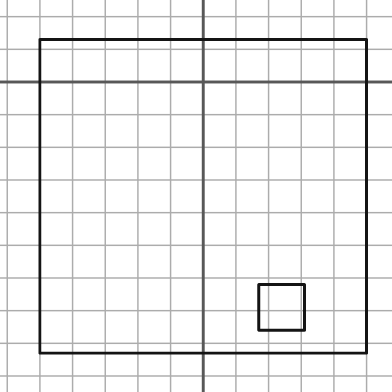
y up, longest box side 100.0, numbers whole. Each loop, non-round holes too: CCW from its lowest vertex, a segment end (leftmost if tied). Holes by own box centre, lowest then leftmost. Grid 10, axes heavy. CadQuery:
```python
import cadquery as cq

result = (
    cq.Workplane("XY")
    .moveTo(-50.0, -83.0)
    .lineTo(50.0, -83.0)
    .lineTo(50.0, 13.0)
    .lineTo(-50.0, 13.0)
    .close()
    .moveTo(17.0, -76.0)
    .lineTo(31.0, -76.0)
    .lineTo(31.0, -62.0)
    .lineTo(17.0, -62.0)
    .close()
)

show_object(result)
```